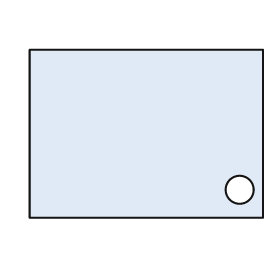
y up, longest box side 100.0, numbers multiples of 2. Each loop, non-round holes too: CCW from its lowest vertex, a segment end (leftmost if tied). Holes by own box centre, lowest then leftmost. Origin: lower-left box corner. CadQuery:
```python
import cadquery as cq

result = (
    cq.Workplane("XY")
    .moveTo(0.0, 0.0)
    .lineTo(100.0, 0.0)
    .lineTo(100.0, 72.0)
    .lineTo(0.0, 72.0)
    .close()
    .moveTo(90.0, 12.0)
    .circle(6.0)
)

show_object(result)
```